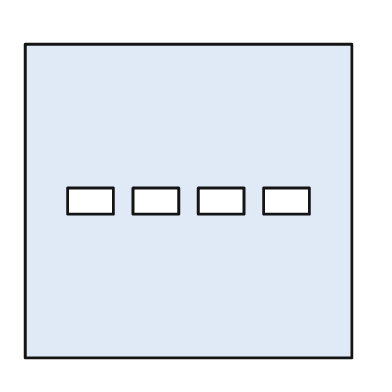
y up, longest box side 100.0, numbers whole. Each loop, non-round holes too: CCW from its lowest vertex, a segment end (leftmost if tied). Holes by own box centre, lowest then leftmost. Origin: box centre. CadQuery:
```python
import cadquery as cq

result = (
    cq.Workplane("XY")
    .moveTo(-50.0, -48.0)
    .lineTo(50.0, -48.0)
    .lineTo(50.0, 48.0)
    .lineTo(-50.0, 48.0)
    .close()
    .moveTo(-37.0, -4.0)
    .lineTo(-23.0, -4.0)
    .lineTo(-23.0, 4.0)
    .lineTo(-37.0, 4.0)
    .close()
    .moveTo(-17.0, -4.0)
    .lineTo(-3.0, -4.0)
    .lineTo(-3.0, 4.0)
    .lineTo(-17.0, 4.0)
    .close()
    .moveTo(3.0, -4.0)
    .lineTo(17.0, -4.0)
    .lineTo(17.0, 4.0)
    .lineTo(3.0, 4.0)
    .close()
    .moveTo(23.0, -4.0)
    .lineTo(37.0, -4.0)
    .lineTo(37.0, 4.0)
    .lineTo(23.0, 4.0)
    .close()
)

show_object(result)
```